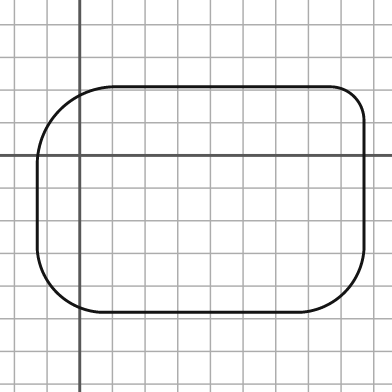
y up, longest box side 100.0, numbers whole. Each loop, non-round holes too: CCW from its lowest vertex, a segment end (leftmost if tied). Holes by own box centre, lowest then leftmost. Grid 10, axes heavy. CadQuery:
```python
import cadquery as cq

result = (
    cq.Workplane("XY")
    .moveTo(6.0, -48.0)
    .lineTo(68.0, -48.0)
    .threePointArc((81.0, -42.0), (87.0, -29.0))
    .lineTo(87.0, 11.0)
    .threePointArc((84.0, 18.0), (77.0, 21.0))
    .lineTo(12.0, 21.0)
    .threePointArc((-6.0, 14.0), (-13.0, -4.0))
    .lineTo(-13.0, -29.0)
    .threePointArc((-7.0, -42.0), (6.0, -48.0))
    .close()
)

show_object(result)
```